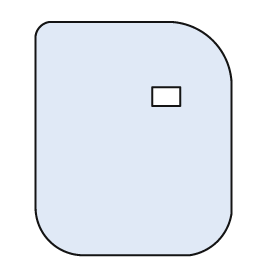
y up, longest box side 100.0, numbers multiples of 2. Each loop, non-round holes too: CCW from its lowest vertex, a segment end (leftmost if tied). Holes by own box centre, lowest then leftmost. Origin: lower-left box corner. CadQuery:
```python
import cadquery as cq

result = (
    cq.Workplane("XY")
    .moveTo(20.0, 0.0)
    .lineTo(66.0, 0.0)
    .threePointArc((78.0, 6.0), (84.0, 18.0))
    .lineTo(84.0, 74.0)
    .threePointArc((76.0, 92.0), (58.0, 100.0))
    .lineTo(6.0, 100.0)
    .threePointArc((2.0, 98.0), (0.0, 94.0))
    .lineTo(0.0, 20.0)
    .threePointArc((6.0, 6.0), (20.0, 0.0))
    .close()
    .moveTo(50.0, 64.0)
    .lineTo(62.0, 64.0)
    .lineTo(62.0, 72.0)
    .lineTo(50.0, 72.0)
    .close()
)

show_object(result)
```